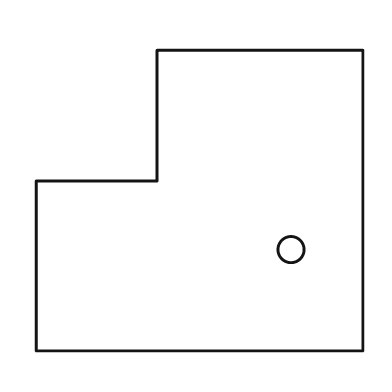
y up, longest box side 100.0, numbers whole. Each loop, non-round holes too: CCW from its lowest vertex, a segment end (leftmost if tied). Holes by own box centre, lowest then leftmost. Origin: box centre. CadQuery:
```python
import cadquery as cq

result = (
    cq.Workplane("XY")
    .moveTo(-50.0, -46.0)
    .lineTo(50.0, -46.0)
    .lineTo(50.0, 46.0)
    .lineTo(-13.0, 46.0)
    .lineTo(-13.0, 6.0)
    .lineTo(-50.0, 6.0)
    .close()
    .moveTo(28.0, -15.0)
    .circle(4.0)
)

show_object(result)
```